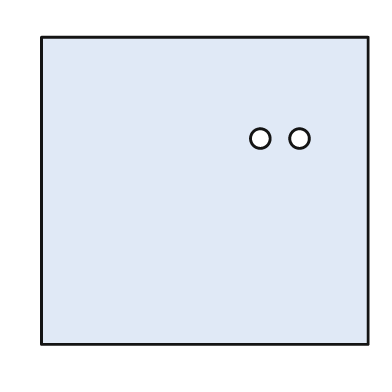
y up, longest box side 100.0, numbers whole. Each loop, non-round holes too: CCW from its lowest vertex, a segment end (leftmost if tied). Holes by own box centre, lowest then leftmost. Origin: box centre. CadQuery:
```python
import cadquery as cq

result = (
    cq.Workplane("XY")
    .moveTo(-50.0, -47.0)
    .lineTo(50.0, -47.0)
    .lineTo(50.0, 47.0)
    .lineTo(-50.0, 47.0)
    .close()
    .moveTo(17.0, 16.0)
    .circle(3.0)
    .moveTo(29.0, 16.0)
    .circle(3.0)
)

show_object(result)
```